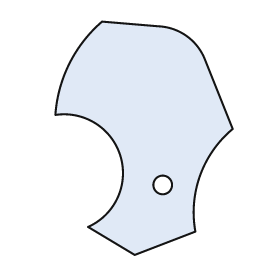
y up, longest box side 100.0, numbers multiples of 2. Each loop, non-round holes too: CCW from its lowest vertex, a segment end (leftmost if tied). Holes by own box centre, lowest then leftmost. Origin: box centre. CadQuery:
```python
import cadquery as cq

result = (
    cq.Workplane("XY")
    .moveTo(-4.0, -50.0)
    .lineTo(22.0, -40.0)
    .threePointArc((24.0, -16.0), (38.0, 4.0))
    .lineTo(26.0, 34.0)
    .threePointArc((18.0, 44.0), (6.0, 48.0))
    .lineTo(-18.0, 50.0)
    .threePointArc((-32.0, 32.0), (-38.0, 10.0))
    .threePointArc((-10.0, -8.0), (-24.0, -38.0))
    .close()
    .moveTo(8.0, -20.0)
    .circle(4.0)
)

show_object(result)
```